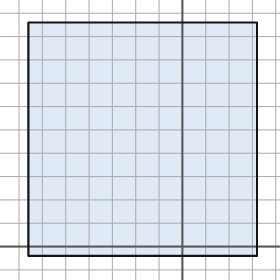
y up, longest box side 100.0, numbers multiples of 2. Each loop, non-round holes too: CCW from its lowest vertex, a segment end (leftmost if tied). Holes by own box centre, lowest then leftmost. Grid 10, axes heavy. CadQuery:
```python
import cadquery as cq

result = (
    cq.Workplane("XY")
    .moveTo(-66.0, -4.0)
    .lineTo(32.0, -4.0)
    .lineTo(32.0, 96.0)
    .lineTo(-66.0, 96.0)
    .close()
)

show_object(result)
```